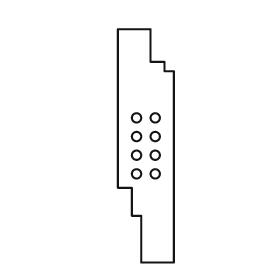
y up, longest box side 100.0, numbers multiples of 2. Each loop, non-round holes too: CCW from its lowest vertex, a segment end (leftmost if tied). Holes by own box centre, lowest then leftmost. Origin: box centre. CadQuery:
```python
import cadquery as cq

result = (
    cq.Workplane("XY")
    .moveTo(-2.0, -50.0)
    .lineTo(12.0, -50.0)
    .lineTo(12.0, 32.0)
    .lineTo(8.0, 32.0)
    .lineTo(8.0, 36.0)
    .lineTo(2.0, 36.0)
    .lineTo(2.0, 50.0)
    .lineTo(-12.0, 50.0)
    .lineTo(-12.0, -18.0)
    .lineTo(-6.0, -18.0)
    .lineTo(-6.0, -30.0)
    .lineTo(-2.0, -30.0)
    .close()
    .moveTo(-4.0, -12.0)
    .circle(2.0)
    .moveTo(4.0, -12.0)
    .circle(2.0)
    .moveTo(-4.0, -4.0)
    .circle(2.0)
    .moveTo(4.0, -4.0)
    .circle(2.0)
    .moveTo(-4.0, 4.0)
    .circle(2.0)
    .moveTo(4.0, 4.0)
    .circle(2.0)
    .moveTo(-4.0, 12.0)
    .circle(2.0)
    .moveTo(4.0, 12.0)
    .circle(2.0)
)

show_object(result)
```